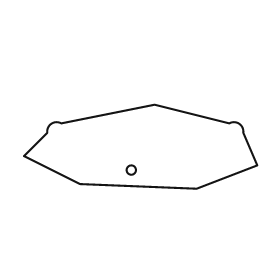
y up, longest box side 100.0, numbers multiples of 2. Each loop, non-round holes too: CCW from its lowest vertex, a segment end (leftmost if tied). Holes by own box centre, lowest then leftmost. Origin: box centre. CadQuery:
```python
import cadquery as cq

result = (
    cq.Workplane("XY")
    .moveTo(24.0, -18.0)
    .lineTo(50.0, -8.0)
    .lineTo(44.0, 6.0)
    .threePointArc((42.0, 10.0), (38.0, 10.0))
    .lineTo(6.0, 18.0)
    .lineTo(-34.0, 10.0)
    .threePointArc((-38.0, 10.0), (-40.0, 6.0))
    .lineTo(-50.0, -4.0)
    .lineTo(-26.0, -16.0)
    .close()
    .moveTo(-4.0, -10.0)
    .circle(2.0)
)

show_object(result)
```